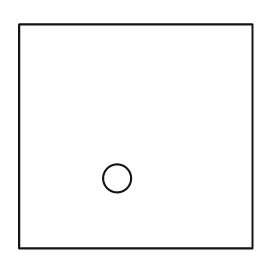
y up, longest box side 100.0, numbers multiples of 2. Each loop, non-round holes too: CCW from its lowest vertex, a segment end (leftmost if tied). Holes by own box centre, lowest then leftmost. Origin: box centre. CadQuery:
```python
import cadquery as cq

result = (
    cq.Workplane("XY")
    .moveTo(-50.0, -48.0)
    .lineTo(50.0, -48.0)
    .lineTo(50.0, 48.0)
    .lineTo(-50.0, 48.0)
    .close()
    .moveTo(-8.0, -18.0)
    .circle(6.0)
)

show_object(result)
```